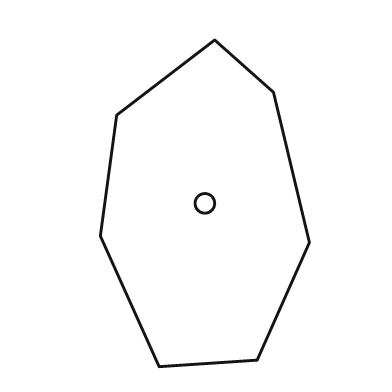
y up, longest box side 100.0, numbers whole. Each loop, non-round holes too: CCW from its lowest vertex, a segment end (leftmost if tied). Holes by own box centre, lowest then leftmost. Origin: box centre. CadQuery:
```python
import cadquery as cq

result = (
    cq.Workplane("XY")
    .moveTo(-14.0, -50.0)
    .lineTo(16.0, -48.0)
    .lineTo(32.0, -12.0)
    .lineTo(21.0, 34.0)
    .lineTo(3.0, 50.0)
    .lineTo(-27.0, 27.0)
    .lineTo(-32.0, -10.0)
    .close()
    .moveTo(0.0, 0.0)
    .circle(3.0)
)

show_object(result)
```